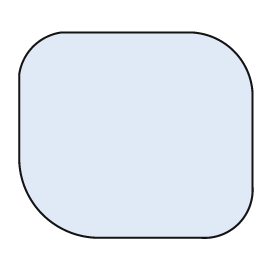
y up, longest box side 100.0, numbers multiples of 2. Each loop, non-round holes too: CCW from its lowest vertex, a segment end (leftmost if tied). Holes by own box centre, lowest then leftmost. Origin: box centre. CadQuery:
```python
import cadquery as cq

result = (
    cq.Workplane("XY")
    .moveTo(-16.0, -44.0)
    .lineTo(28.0, -44.0)
    .threePointArc((44.0, -38.0), (50.0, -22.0))
    .lineTo(50.0, 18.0)
    .threePointArc((42.0, 36.0), (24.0, 44.0))
    .lineTo(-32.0, 44.0)
    .threePointArc((-44.0, 38.0), (-50.0, 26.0))
    .lineTo(-50.0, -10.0)
    .threePointArc((-40.0, -34.0), (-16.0, -44.0))
    .close()
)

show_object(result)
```